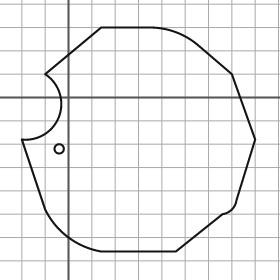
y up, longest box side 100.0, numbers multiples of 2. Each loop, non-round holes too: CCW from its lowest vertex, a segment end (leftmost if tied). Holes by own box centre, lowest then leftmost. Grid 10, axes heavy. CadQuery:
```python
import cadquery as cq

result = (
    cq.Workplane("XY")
    .moveTo(14.0, -66.0)
    .lineTo(46.0, -66.0)
    .lineTo(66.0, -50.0)
    .threePointArc((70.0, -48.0), (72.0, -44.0))
    .lineTo(80.0, -18.0)
    .lineTo(70.0, 10.0)
    .lineTo(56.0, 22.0)
    .threePointArc((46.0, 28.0), (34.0, 30.0))
    .lineTo(14.0, 30.0)
    .lineTo(-10.0, 10.0)
    .threePointArc((-4.0, -8.0), (-20.0, -18.0))
    .lineTo(-10.0, -48.0)
    .threePointArc((0.0, -60.0), (14.0, -66.0))
    .close()
    .moveTo(-4.0, -22.0)
    .circle(2.0)
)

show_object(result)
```